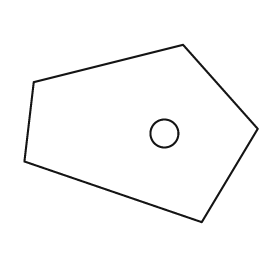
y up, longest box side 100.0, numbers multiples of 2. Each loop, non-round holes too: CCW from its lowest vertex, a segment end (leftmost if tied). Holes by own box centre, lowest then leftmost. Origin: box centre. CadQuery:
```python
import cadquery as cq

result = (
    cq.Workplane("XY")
    .moveTo(26.0, -38.0)
    .lineTo(50.0, 2.0)
    .lineTo(18.0, 38.0)
    .lineTo(-46.0, 22.0)
    .lineTo(-50.0, -12.0)
    .close()
    .moveTo(10.0, 0.0)
    .circle(6.0)
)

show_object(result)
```